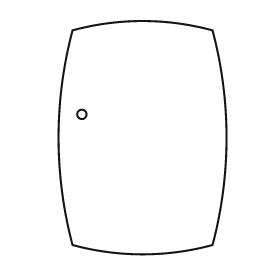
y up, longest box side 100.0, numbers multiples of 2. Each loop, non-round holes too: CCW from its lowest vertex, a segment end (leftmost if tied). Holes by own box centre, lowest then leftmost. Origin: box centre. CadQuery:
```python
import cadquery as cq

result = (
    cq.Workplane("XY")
    .moveTo(-30.0, -46.0)
    .threePointArc((0.0, -50.0), (30.0, -46.0))
    .threePointArc((36.0, 0.0), (30.0, 46.0))
    .threePointArc((0.0, 50.0), (-30.0, 46.0))
    .threePointArc((-36.0, 0.0), (-30.0, -46.0))
    .close()
    .moveTo(-26.0, 10.0)
    .circle(2.0)
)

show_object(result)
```